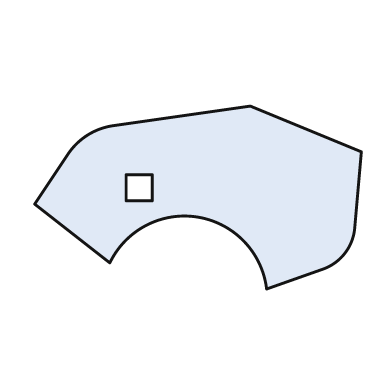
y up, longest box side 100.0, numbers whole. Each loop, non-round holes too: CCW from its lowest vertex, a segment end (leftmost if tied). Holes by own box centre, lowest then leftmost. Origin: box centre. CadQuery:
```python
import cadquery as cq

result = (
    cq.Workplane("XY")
    .moveTo(21.0, -28.0)
    .lineTo(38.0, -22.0)
    .threePointArc((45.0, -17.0), (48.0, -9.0))
    .lineTo(50.0, 14.0)
    .lineTo(16.0, 28.0)
    .lineTo(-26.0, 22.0)
    .threePointArc((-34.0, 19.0), (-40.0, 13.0))
    .lineTo(-50.0, -2.0)
    .lineTo(-27.0, -20.0)
    .threePointArc((0.0, -6.0), (21.0, -28.0))
    .close()
    .moveTo(-22.0, -1.0)
    .lineTo(-14.0, -1.0)
    .lineTo(-14.0, 7.0)
    .lineTo(-22.0, 7.0)
    .close()
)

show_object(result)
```